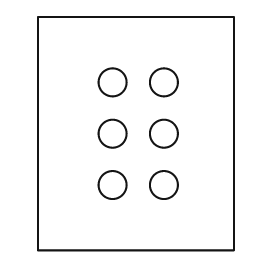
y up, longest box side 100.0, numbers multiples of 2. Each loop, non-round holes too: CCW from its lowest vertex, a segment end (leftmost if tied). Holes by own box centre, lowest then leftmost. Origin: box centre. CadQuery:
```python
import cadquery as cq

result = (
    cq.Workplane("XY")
    .moveTo(-42.0, -50.0)
    .lineTo(42.0, -50.0)
    .lineTo(42.0, 50.0)
    .lineTo(-42.0, 50.0)
    .close()
    .moveTo(-10.0, -22.0)
    .circle(6.0)
    .moveTo(12.0, -22.0)
    .circle(6.0)
    .moveTo(-10.0, 0.0)
    .circle(6.0)
    .moveTo(12.0, 0.0)
    .circle(6.0)
    .moveTo(-10.0, 22.0)
    .circle(6.0)
    .moveTo(12.0, 22.0)
    .circle(6.0)
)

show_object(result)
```